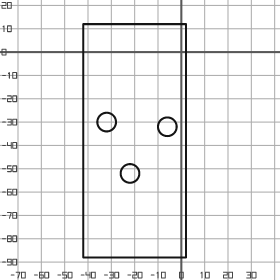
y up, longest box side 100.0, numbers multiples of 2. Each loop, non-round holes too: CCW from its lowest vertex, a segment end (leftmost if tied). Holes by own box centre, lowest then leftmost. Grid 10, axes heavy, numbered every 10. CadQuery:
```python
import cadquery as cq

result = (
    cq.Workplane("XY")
    .moveTo(-42.0, -88.0)
    .lineTo(2.0, -88.0)
    .lineTo(2.0, 12.0)
    .lineTo(-42.0, 12.0)
    .close()
    .moveTo(-22.0, -52.0)
    .circle(4.0)
    .moveTo(-6.0, -32.0)
    .circle(4.0)
    .moveTo(-32.0, -30.0)
    .circle(4.0)
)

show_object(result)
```